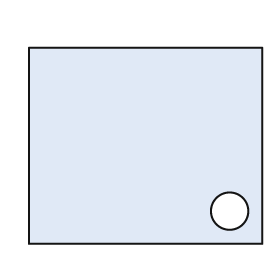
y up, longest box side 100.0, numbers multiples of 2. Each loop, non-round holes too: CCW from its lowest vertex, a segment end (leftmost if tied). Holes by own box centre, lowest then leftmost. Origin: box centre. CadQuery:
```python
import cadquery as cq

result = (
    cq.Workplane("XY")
    .moveTo(-50.0, -42.0)
    .lineTo(50.0, -42.0)
    .lineTo(50.0, 42.0)
    .lineTo(-50.0, 42.0)
    .close()
    .moveTo(36.0, -28.0)
    .circle(8.0)
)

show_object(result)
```